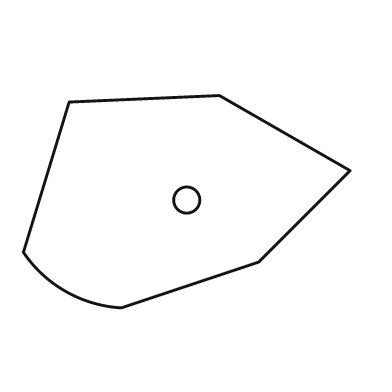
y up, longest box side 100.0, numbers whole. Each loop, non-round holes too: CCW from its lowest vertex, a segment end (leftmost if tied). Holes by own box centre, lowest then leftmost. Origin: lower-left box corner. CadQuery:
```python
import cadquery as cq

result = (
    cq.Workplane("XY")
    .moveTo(30.0, 0.0)
    .lineTo(72.0, 14.0)
    .lineTo(100.0, 42.0)
    .lineTo(60.0, 65.0)
    .lineTo(14.0, 63.0)
    .lineTo(0.0, 17.0)
    .threePointArc((13.0, 5.0), (30.0, 0.0))
    .close()
    .moveTo(50.0, 33.0)
    .circle(4.0)
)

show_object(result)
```